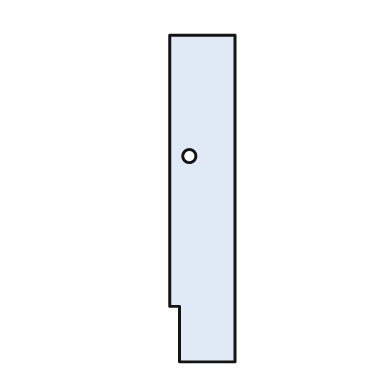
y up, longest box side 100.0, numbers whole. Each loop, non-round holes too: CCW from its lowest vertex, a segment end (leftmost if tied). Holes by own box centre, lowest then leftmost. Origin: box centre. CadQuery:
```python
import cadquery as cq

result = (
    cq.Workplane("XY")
    .moveTo(-7.0, -50.0)
    .lineTo(10.0, -50.0)
    .lineTo(10.0, 50.0)
    .lineTo(-10.0, 50.0)
    .lineTo(-10.0, -33.0)
    .lineTo(-7.0, -33.0)
    .close()
    .moveTo(-4.0, 13.0)
    .circle(2.0)
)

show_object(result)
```